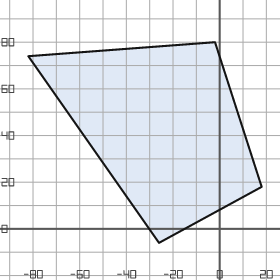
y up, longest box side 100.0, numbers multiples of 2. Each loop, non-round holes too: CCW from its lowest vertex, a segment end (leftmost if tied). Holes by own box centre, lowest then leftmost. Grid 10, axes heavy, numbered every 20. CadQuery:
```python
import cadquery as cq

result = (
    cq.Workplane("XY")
    .moveTo(-26.0, -6.0)
    .lineTo(18.0, 18.0)
    .lineTo(-2.0, 80.0)
    .lineTo(-82.0, 74.0)
    .close()
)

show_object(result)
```